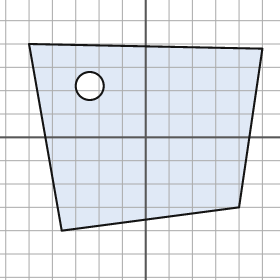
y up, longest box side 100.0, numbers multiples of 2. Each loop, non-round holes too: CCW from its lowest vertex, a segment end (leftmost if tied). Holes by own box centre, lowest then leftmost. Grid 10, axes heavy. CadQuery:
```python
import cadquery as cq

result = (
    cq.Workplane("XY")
    .moveTo(-36.0, -40.0)
    .lineTo(40.0, -30.0)
    .lineTo(50.0, 38.0)
    .lineTo(-50.0, 40.0)
    .close()
    .moveTo(-24.0, 22.0)
    .circle(6.0)
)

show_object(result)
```